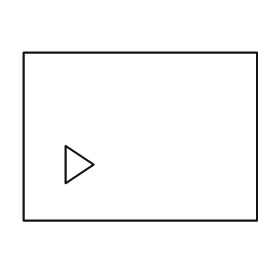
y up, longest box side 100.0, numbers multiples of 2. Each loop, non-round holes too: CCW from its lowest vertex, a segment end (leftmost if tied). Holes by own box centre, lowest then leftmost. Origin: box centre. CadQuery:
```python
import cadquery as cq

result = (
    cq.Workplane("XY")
    .moveTo(-50.0, -36.0)
    .lineTo(50.0, -36.0)
    .lineTo(50.0, 36.0)
    .lineTo(-50.0, 36.0)
    .close()
    .moveTo(-32.0, -20.0)
    .lineTo(-20.0, -12.0)
    .lineTo(-32.0, -4.0)
    .close()
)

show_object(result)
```